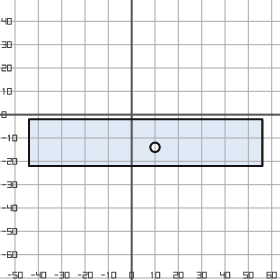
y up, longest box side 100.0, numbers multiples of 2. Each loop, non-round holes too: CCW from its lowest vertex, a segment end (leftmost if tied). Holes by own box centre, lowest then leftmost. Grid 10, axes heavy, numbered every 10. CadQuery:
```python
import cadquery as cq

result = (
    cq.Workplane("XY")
    .moveTo(-44.0, -22.0)
    .lineTo(56.0, -22.0)
    .lineTo(56.0, -2.0)
    .lineTo(-44.0, -2.0)
    .close()
    .moveTo(10.0, -14.0)
    .circle(2.0)
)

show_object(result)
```